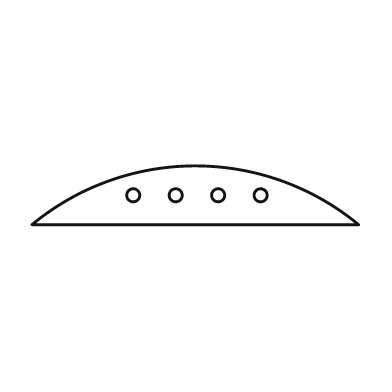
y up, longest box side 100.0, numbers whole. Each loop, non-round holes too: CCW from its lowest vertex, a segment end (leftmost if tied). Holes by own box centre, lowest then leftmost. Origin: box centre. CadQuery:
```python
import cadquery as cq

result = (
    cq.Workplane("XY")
    .moveTo(-50.0, -9.0)
    .lineTo(50.0, -9.0)
    .threePointArc((0.0, 9.0), (-50.0, -9.0))
    .close()
    .moveTo(-19.0, 0.0)
    .circle(2.0)
    .moveTo(-6.0, 0.0)
    .circle(2.0)
    .moveTo(7.0, 0.0)
    .circle(2.0)
    .moveTo(20.0, 0.0)
    .circle(2.0)
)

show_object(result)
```